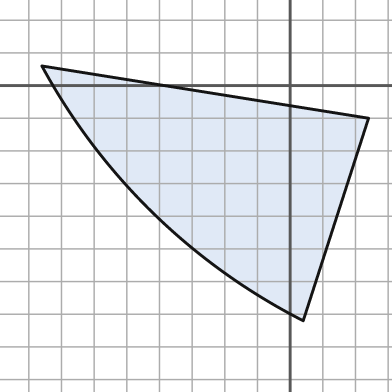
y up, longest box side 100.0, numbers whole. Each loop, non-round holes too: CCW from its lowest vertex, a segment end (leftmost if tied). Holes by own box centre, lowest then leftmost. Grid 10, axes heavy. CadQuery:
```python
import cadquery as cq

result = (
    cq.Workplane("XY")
    .moveTo(4.0, -72.0)
    .lineTo(24.0, -10.0)
    .lineTo(-76.0, 6.0)
    .threePointArc((-42.0, -39.0), (4.0, -72.0))
    .close()
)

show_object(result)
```